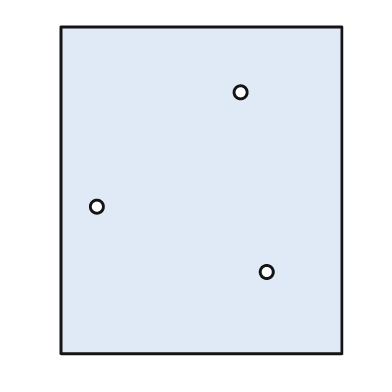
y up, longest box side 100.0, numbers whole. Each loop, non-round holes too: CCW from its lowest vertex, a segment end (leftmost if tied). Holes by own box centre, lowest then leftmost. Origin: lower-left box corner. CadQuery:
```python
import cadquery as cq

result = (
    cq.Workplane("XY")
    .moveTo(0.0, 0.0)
    .lineTo(86.0, 0.0)
    .lineTo(86.0, 100.0)
    .lineTo(0.0, 100.0)
    .close()
    .moveTo(63.0, 25.0)
    .circle(2.0)
    .moveTo(11.0, 45.0)
    .circle(2.0)
    .moveTo(55.0, 80.0)
    .circle(2.0)
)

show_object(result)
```